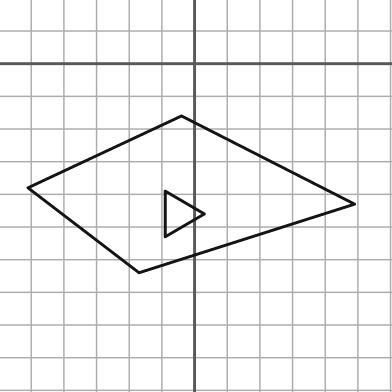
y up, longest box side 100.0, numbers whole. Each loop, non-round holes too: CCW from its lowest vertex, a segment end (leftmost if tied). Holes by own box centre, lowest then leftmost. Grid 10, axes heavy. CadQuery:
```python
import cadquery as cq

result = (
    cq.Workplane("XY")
    .moveTo(-17.0, -64.0)
    .lineTo(49.0, -43.0)
    .lineTo(-4.0, -16.0)
    .lineTo(-51.0, -38.0)
    .close()
    .moveTo(-9.0, -53.0)
    .lineTo(3.0, -46.0)
    .lineTo(-9.0, -39.0)
    .close()
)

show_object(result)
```